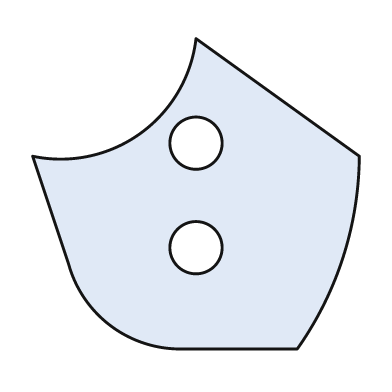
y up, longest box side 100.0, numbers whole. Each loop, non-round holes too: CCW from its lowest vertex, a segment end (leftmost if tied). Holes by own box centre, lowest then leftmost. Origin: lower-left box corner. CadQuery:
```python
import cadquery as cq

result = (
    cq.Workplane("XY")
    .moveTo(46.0, 0.0)
    .lineTo(81.0, 0.0)
    .threePointArc((95.0, 28.0), (100.0, 59.0))
    .lineTo(50.0, 95.0)
    .threePointArc((33.0, 66.0), (0.0, 59.0))
    .lineTo(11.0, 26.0)
    .threePointArc((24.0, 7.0), (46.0, 0.0))
    .close()
    .moveTo(50.0, 31.0)
    .circle(8.0)
    .moveTo(50.0, 63.0)
    .circle(8.0)
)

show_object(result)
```